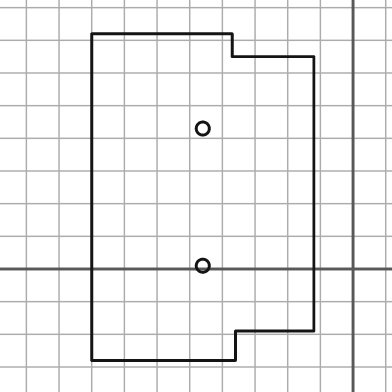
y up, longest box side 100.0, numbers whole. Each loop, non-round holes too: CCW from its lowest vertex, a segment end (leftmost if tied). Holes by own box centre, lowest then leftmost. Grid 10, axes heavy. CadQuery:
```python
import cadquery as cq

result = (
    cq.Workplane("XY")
    .moveTo(-80.0, -28.0)
    .lineTo(-36.0, -28.0)
    .lineTo(-36.0, -19.0)
    .lineTo(-12.0, -19.0)
    .lineTo(-12.0, 65.0)
    .lineTo(-37.0, 65.0)
    .lineTo(-37.0, 72.0)
    .lineTo(-80.0, 72.0)
    .close()
    .moveTo(-46.0, 1.0)
    .circle(2.0)
    .moveTo(-46.0, 43.0)
    .circle(2.0)
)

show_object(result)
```